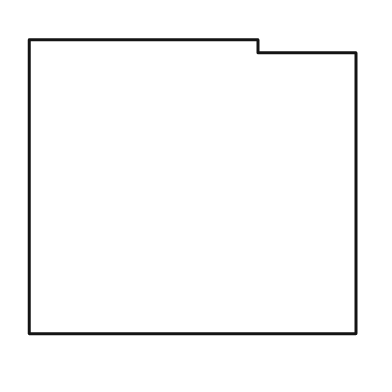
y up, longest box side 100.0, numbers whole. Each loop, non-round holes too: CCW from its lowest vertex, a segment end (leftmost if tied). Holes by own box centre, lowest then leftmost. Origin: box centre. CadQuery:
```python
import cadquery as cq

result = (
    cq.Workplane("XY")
    .moveTo(-50.0, -45.0)
    .lineTo(50.0, -45.0)
    .lineTo(50.0, 41.0)
    .lineTo(20.0, 41.0)
    .lineTo(20.0, 45.0)
    .lineTo(-50.0, 45.0)
    .close()
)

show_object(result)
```